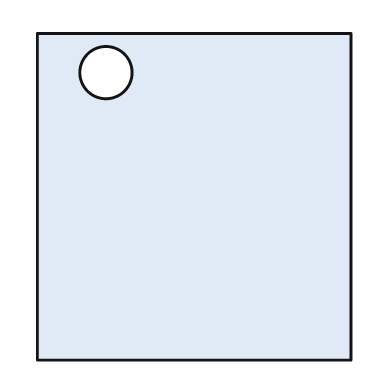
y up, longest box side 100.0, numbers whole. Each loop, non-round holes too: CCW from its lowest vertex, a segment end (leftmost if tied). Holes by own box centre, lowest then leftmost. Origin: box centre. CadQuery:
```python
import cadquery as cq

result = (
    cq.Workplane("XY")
    .moveTo(-48.0, -50.0)
    .lineTo(48.0, -50.0)
    .lineTo(48.0, 50.0)
    .lineTo(-48.0, 50.0)
    .close()
    .moveTo(-27.0, 38.0)
    .circle(8.0)
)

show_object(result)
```